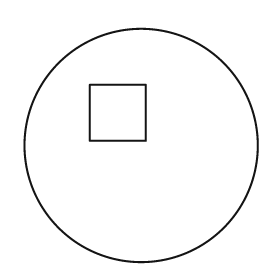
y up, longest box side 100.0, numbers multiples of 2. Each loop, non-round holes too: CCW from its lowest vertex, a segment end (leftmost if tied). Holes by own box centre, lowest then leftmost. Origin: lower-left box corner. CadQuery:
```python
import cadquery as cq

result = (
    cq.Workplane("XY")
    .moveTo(50.0, 50.0)
    .circle(50.0)
    .moveTo(28.0, 52.0)
    .lineTo(52.0, 52.0)
    .lineTo(52.0, 76.0)
    .lineTo(28.0, 76.0)
    .close()
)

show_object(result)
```